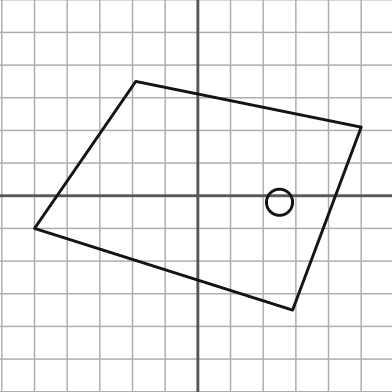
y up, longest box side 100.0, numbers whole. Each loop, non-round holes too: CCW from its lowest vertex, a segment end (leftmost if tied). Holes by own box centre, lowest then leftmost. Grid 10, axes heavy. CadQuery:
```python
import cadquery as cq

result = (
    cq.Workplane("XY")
    .moveTo(29.0, -35.0)
    .lineTo(50.0, 21.0)
    .lineTo(-19.0, 35.0)
    .lineTo(-50.0, -10.0)
    .close()
    .moveTo(25.0, -2.0)
    .circle(4.0)
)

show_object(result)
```